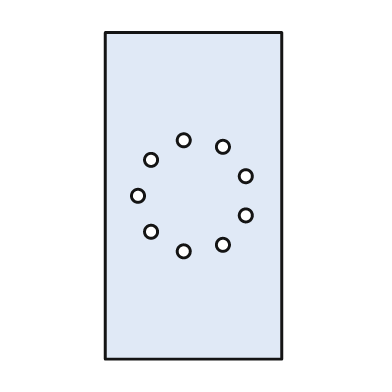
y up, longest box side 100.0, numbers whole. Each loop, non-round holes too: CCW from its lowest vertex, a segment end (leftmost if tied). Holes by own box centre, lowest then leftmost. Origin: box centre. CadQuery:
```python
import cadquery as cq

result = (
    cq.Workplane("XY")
    .moveTo(-27.0, -50.0)
    .lineTo(27.0, -50.0)
    .lineTo(27.0, 50.0)
    .lineTo(-27.0, 50.0)
    .close()
    .moveTo(-3.0, -17.0)
    .circle(2.0)
    .moveTo(9.0, -15.0)
    .circle(2.0)
    .moveTo(-13.0, -11.0)
    .circle(2.0)
    .moveTo(16.0, -6.0)
    .circle(2.0)
    .moveTo(-17.0, 0.0)
    .circle(2.0)
    .moveTo(16.0, 6.0)
    .circle(2.0)
    .moveTo(-13.0, 11.0)
    .circle(2.0)
    .moveTo(9.0, 15.0)
    .circle(2.0)
    .moveTo(-3.0, 17.0)
    .circle(2.0)
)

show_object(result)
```